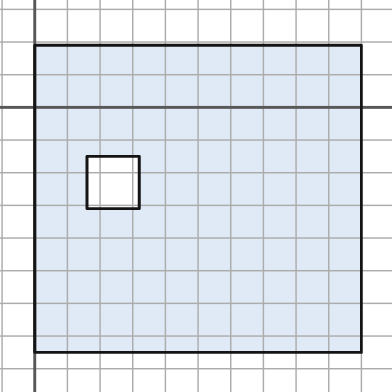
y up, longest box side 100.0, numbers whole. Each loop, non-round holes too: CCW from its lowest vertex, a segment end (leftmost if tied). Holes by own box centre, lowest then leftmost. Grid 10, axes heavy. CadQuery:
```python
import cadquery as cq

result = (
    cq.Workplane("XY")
    .moveTo(0.0, -75.0)
    .lineTo(100.0, -75.0)
    .lineTo(100.0, 19.0)
    .lineTo(0.0, 19.0)
    .close()
    .moveTo(16.0, -31.0)
    .lineTo(32.0, -31.0)
    .lineTo(32.0, -15.0)
    .lineTo(16.0, -15.0)
    .close()
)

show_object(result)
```